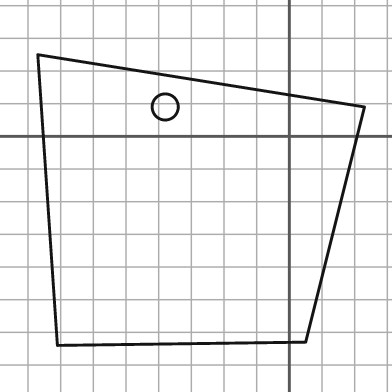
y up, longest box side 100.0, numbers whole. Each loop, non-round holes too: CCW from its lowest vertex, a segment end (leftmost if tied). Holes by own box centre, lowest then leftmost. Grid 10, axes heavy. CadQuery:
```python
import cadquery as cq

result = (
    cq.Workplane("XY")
    .moveTo(-71.0, -64.0)
    .lineTo(5.0, -63.0)
    .lineTo(23.0, 9.0)
    .lineTo(-77.0, 25.0)
    .close()
    .moveTo(-38.0, 9.0)
    .circle(4.0)
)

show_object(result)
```